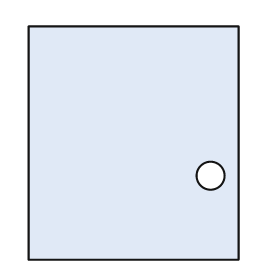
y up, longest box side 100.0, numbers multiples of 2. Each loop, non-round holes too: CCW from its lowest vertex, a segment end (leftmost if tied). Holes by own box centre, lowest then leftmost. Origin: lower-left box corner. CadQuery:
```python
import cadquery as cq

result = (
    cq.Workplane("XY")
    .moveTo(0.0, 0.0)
    .lineTo(90.0, 0.0)
    .lineTo(90.0, 100.0)
    .lineTo(0.0, 100.0)
    .close()
    .moveTo(78.0, 36.0)
    .circle(6.0)
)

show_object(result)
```